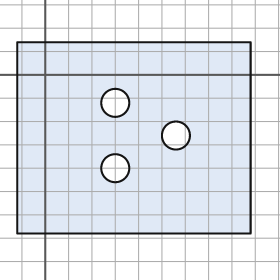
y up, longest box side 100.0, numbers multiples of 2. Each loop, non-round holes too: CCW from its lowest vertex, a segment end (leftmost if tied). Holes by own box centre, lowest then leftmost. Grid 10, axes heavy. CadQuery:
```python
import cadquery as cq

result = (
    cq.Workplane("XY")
    .moveTo(-12.0, -68.0)
    .lineTo(88.0, -68.0)
    .lineTo(88.0, 14.0)
    .lineTo(-12.0, 14.0)
    .close()
    .moveTo(30.0, -40.0)
    .circle(6.0)
    .moveTo(56.0, -26.0)
    .circle(6.0)
    .moveTo(30.0, -12.0)
    .circle(6.0)
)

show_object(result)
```